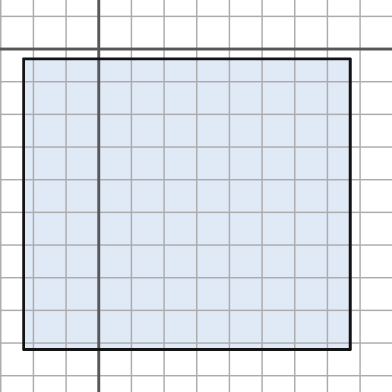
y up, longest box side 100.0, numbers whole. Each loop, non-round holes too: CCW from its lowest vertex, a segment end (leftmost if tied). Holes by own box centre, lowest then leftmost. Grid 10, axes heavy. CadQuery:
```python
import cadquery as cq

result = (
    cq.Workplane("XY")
    .moveTo(-23.0, -92.0)
    .lineTo(77.0, -92.0)
    .lineTo(77.0, -3.0)
    .lineTo(-23.0, -3.0)
    .close()
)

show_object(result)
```